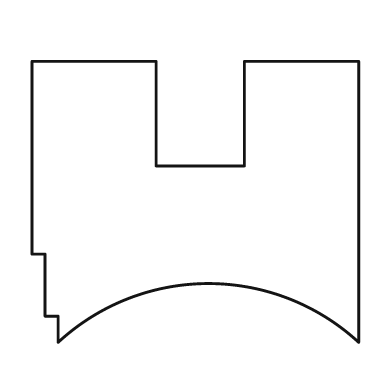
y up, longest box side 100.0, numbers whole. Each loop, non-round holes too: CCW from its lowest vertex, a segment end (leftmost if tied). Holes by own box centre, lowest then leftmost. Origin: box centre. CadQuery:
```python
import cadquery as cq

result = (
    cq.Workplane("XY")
    .moveTo(-42.0, -43.0)
    .threePointArc((4.0, -25.0), (50.0, -43.0))
    .lineTo(50.0, 43.0)
    .lineTo(15.0, 43.0)
    .lineTo(15.0, 11.0)
    .lineTo(-12.0, 11.0)
    .lineTo(-12.0, 43.0)
    .lineTo(-50.0, 43.0)
    .lineTo(-50.0, -16.0)
    .lineTo(-46.0, -16.0)
    .lineTo(-46.0, -35.0)
    .lineTo(-42.0, -35.0)
    .close()
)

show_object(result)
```